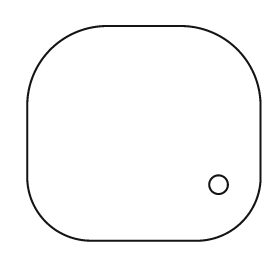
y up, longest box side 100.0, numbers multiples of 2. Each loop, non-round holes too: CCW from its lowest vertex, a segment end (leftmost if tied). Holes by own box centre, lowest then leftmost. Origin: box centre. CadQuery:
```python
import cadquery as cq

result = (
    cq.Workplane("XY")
    .moveTo(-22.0, -46.0)
    .lineTo(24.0, -46.0)
    .threePointArc((42.0, -38.0), (50.0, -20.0))
    .lineTo(50.0, 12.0)
    .threePointArc((40.0, 36.0), (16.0, 46.0))
    .lineTo(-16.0, 46.0)
    .threePointArc((-40.0, 36.0), (-50.0, 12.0))
    .lineTo(-50.0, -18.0)
    .threePointArc((-42.0, -38.0), (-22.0, -46.0))
    .close()
    .moveTo(32.0, -22.0)
    .circle(4.0)
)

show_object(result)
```